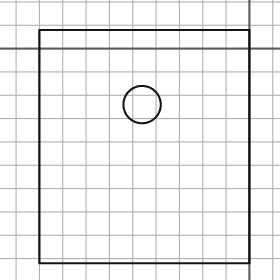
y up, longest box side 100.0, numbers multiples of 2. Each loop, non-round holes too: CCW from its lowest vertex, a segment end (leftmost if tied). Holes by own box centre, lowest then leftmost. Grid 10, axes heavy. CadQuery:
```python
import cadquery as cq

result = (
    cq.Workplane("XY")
    .moveTo(-90.0, -92.0)
    .lineTo(0.0, -92.0)
    .lineTo(0.0, 8.0)
    .lineTo(-90.0, 8.0)
    .close()
    .moveTo(-46.0, -24.0)
    .circle(8.0)
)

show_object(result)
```